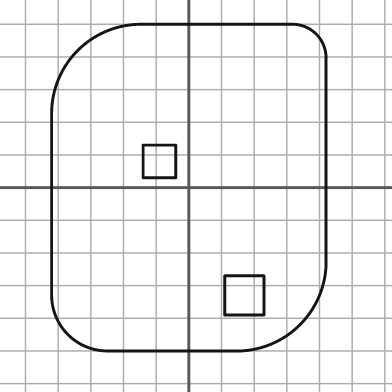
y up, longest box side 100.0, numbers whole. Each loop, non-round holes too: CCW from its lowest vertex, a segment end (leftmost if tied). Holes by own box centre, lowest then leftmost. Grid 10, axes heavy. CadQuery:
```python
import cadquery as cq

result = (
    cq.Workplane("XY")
    .moveTo(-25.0, -50.0)
    .lineTo(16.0, -50.0)
    .threePointArc((34.0, -42.0), (42.0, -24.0))
    .lineTo(42.0, 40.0)
    .threePointArc((39.0, 47.0), (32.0, 50.0))
    .lineTo(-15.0, 50.0)
    .threePointArc((-34.0, 42.0), (-42.0, 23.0))
    .lineTo(-42.0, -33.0)
    .threePointArc((-37.0, -45.0), (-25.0, -50.0))
    .close()
    .moveTo(11.0, -39.0)
    .lineTo(23.0, -39.0)
    .lineTo(23.0, -27.0)
    .lineTo(11.0, -27.0)
    .close()
    .moveTo(-14.0, 3.0)
    .lineTo(-4.0, 3.0)
    .lineTo(-4.0, 13.0)
    .lineTo(-14.0, 13.0)
    .close()
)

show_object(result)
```